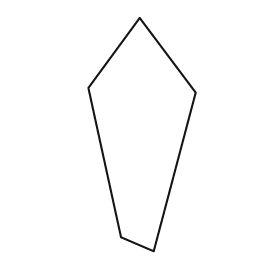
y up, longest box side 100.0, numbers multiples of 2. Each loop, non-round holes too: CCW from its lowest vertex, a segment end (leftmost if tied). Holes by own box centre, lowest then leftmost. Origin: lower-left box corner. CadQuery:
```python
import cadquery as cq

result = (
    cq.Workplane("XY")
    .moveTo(28.0, 0.0)
    .lineTo(46.0, 68.0)
    .lineTo(22.0, 100.0)
    .lineTo(0.0, 70.0)
    .lineTo(14.0, 6.0)
    .close()
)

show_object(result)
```